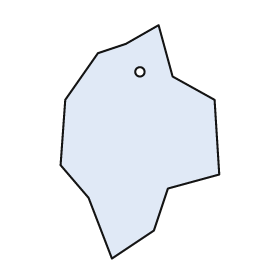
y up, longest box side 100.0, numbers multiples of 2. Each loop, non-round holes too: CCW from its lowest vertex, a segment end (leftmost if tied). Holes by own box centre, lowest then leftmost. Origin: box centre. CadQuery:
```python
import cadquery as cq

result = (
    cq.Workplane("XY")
    .moveTo(-12.0, -50.0)
    .lineTo(6.0, -38.0)
    .lineTo(12.0, -20.0)
    .lineTo(34.0, -14.0)
    .lineTo(32.0, 18.0)
    .lineTo(14.0, 28.0)
    .lineTo(8.0, 50.0)
    .lineTo(-6.0, 42.0)
    .lineTo(-18.0, 38.0)
    .lineTo(-32.0, 18.0)
    .lineTo(-34.0, -10.0)
    .lineTo(-22.0, -24.0)
    .close()
    .moveTo(0.0, 30.0)
    .circle(2.0)
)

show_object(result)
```